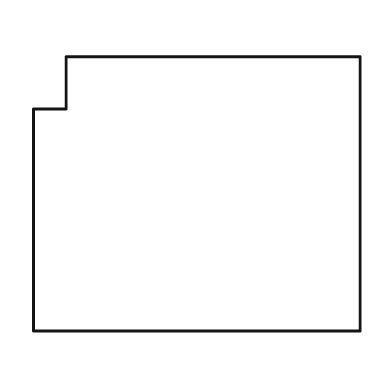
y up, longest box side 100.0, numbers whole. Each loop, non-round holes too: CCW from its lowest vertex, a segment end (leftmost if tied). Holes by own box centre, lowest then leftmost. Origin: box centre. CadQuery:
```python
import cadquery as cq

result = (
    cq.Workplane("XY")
    .moveTo(-50.0, -42.0)
    .lineTo(50.0, -42.0)
    .lineTo(50.0, 42.0)
    .lineTo(-40.0, 42.0)
    .lineTo(-40.0, 26.0)
    .lineTo(-50.0, 26.0)
    .close()
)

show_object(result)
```